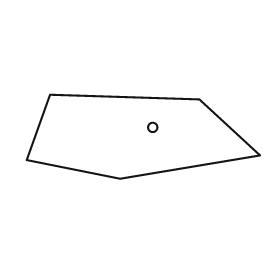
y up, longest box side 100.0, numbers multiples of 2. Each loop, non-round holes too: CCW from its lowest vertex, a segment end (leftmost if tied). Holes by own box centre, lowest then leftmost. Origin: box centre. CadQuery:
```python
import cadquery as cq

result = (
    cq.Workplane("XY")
    .moveTo(-10.0, -18.0)
    .lineTo(50.0, -8.0)
    .lineTo(24.0, 16.0)
    .lineTo(-40.0, 18.0)
    .lineTo(-50.0, -10.0)
    .close()
    .moveTo(4.0, 4.0)
    .circle(2.0)
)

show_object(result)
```